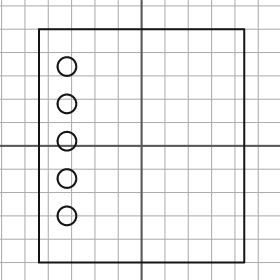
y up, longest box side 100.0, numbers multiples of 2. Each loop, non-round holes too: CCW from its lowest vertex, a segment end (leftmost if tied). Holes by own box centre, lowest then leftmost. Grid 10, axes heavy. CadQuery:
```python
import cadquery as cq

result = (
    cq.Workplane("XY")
    .moveTo(-44.0, -50.0)
    .lineTo(44.0, -50.0)
    .lineTo(44.0, 50.0)
    .lineTo(-44.0, 50.0)
    .close()
    .moveTo(-32.0, -30.0)
    .circle(4.0)
    .moveTo(-32.0, -14.0)
    .circle(4.0)
    .moveTo(-32.0, 2.0)
    .circle(4.0)
    .moveTo(-32.0, 18.0)
    .circle(4.0)
    .moveTo(-32.0, 34.0)
    .circle(4.0)
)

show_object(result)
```